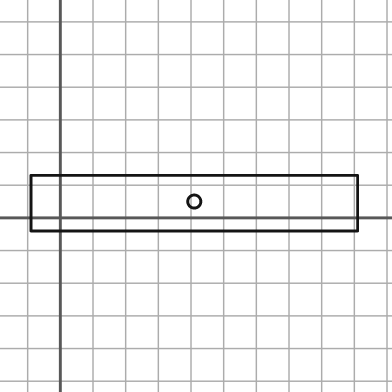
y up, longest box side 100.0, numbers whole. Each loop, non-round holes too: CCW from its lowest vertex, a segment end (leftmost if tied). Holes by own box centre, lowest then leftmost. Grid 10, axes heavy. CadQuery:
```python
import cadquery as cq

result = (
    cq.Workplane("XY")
    .moveTo(-9.0, -4.0)
    .lineTo(91.0, -4.0)
    .lineTo(91.0, 13.0)
    .lineTo(-9.0, 13.0)
    .close()
    .moveTo(41.0, 5.0)
    .circle(2.0)
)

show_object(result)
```